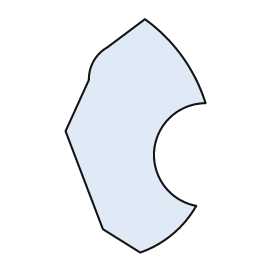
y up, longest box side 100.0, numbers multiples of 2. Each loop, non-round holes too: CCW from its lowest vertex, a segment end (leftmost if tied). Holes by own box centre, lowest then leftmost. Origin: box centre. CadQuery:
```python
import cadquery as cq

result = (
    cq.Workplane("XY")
    .moveTo(2.0, -50.0)
    .threePointArc((16.0, -42.0), (26.0, -30.0))
    .threePointArc((8.0, -6.0), (30.0, 14.0))
    .threePointArc((20.0, 34.0), (4.0, 50.0))
    .lineTo(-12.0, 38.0)
    .threePointArc((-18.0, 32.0), (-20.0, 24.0))
    .lineTo(-30.0, 2.0)
    .lineTo(-14.0, -40.0)
    .close()
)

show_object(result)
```